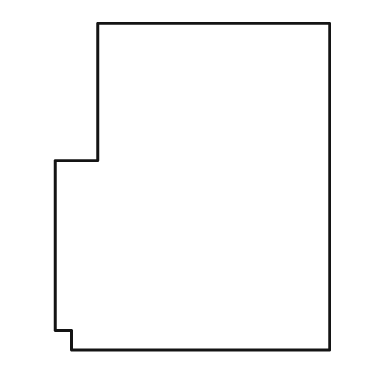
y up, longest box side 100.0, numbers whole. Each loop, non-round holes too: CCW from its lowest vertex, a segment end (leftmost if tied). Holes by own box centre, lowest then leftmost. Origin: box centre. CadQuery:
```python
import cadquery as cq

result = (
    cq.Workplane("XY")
    .moveTo(-37.0, -50.0)
    .lineTo(42.0, -50.0)
    .lineTo(42.0, 50.0)
    .lineTo(-29.0, 50.0)
    .lineTo(-29.0, 8.0)
    .lineTo(-42.0, 8.0)
    .lineTo(-42.0, -44.0)
    .lineTo(-37.0, -44.0)
    .close()
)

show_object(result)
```